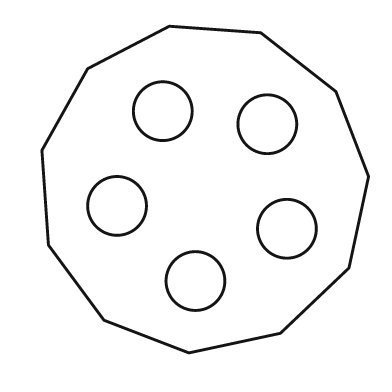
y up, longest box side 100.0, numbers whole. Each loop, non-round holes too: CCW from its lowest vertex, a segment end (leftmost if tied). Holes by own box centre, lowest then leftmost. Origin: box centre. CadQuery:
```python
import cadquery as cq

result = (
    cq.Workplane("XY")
    .moveTo(-5.0, -50.0)
    .lineTo(23.0, -44.0)
    .lineTo(44.0, -24.0)
    .lineTo(50.0, 4.0)
    .lineTo(40.0, 30.0)
    .lineTo(17.0, 48.0)
    .lineTo(-11.0, 50.0)
    .lineTo(-36.0, 37.0)
    .lineTo(-50.0, 12.0)
    .lineTo(-48.0, -17.0)
    .lineTo(-31.0, -40.0)
    .close()
    .moveTo(-3.0, -28.0)
    .circle(9.0)
    .moveTo(25.0, -12.0)
    .circle(9.0)
    .moveTo(-27.0, -5.0)
    .circle(9.0)
    .moveTo(19.0, 20.0)
    .circle(9.0)
    .moveTo(-13.0, 24.0)
    .circle(9.0)
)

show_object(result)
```